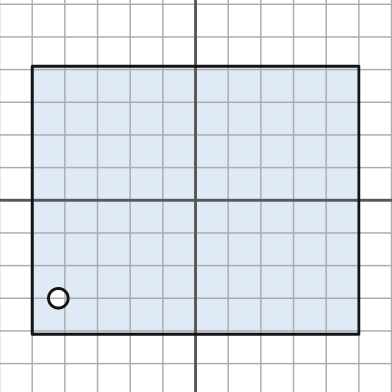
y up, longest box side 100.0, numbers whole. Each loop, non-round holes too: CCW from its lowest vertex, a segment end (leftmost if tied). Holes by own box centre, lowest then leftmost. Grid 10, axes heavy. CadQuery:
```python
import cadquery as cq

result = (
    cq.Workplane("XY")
    .moveTo(-50.0, -41.0)
    .lineTo(50.0, -41.0)
    .lineTo(50.0, 41.0)
    .lineTo(-50.0, 41.0)
    .close()
    .moveTo(-42.0, -30.0)
    .circle(3.0)
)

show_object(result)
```